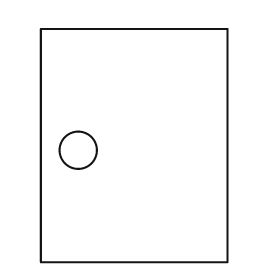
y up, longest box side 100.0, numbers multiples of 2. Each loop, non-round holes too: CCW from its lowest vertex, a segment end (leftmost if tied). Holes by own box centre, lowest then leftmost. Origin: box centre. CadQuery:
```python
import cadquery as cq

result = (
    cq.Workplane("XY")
    .moveTo(-40.0, -50.0)
    .lineTo(40.0, -50.0)
    .lineTo(40.0, 50.0)
    .lineTo(-40.0, 50.0)
    .close()
    .moveTo(-24.0, -2.0)
    .circle(8.0)
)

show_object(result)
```